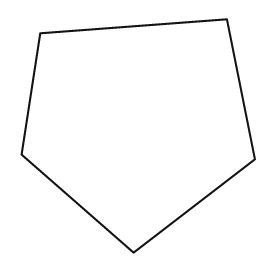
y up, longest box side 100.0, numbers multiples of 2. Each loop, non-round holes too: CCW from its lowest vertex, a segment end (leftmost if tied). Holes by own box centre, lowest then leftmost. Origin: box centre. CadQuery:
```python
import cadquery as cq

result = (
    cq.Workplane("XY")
    .moveTo(-2.0, -50.0)
    .lineTo(50.0, -10.0)
    .lineTo(38.0, 50.0)
    .lineTo(-42.0, 44.0)
    .lineTo(-50.0, -8.0)
    .close()
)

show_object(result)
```